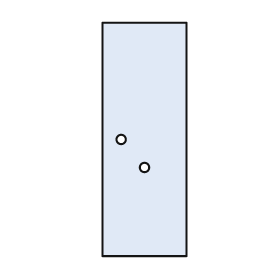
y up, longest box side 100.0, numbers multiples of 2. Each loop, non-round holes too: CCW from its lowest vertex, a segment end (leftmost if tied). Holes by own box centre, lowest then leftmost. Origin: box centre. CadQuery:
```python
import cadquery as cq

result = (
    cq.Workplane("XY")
    .moveTo(-18.0, -50.0)
    .lineTo(18.0, -50.0)
    .lineTo(18.0, 50.0)
    .lineTo(-18.0, 50.0)
    .close()
    .moveTo(0.0, -12.0)
    .circle(2.0)
    .moveTo(-10.0, 0.0)
    .circle(2.0)
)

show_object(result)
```